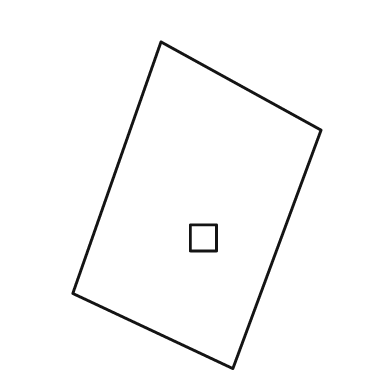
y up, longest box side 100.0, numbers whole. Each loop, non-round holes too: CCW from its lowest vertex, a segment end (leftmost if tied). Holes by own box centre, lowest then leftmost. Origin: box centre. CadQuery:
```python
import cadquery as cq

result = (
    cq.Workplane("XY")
    .moveTo(11.0, -50.0)
    .lineTo(38.0, 23.0)
    .lineTo(-11.0, 50.0)
    .lineTo(-38.0, -27.0)
    .close()
    .moveTo(-2.0, -14.0)
    .lineTo(6.0, -14.0)
    .lineTo(6.0, -6.0)
    .lineTo(-2.0, -6.0)
    .close()
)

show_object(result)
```